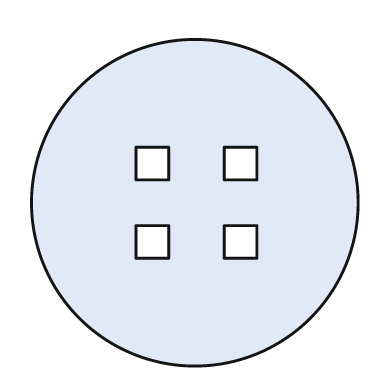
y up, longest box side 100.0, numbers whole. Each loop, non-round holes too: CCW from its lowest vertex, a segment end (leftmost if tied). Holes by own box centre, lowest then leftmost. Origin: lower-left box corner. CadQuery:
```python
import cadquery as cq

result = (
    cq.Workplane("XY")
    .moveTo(50.0, 50.0)
    .circle(50.0)
    .moveTo(32.0, 33.0)
    .lineTo(42.0, 33.0)
    .lineTo(42.0, 43.0)
    .lineTo(32.0, 43.0)
    .close()
    .moveTo(59.0, 33.0)
    .lineTo(69.0, 33.0)
    .lineTo(69.0, 43.0)
    .lineTo(59.0, 43.0)
    .close()
    .moveTo(32.0, 57.0)
    .lineTo(42.0, 57.0)
    .lineTo(42.0, 67.0)
    .lineTo(32.0, 67.0)
    .close()
    .moveTo(59.0, 57.0)
    .lineTo(69.0, 57.0)
    .lineTo(69.0, 67.0)
    .lineTo(59.0, 67.0)
    .close()
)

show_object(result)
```